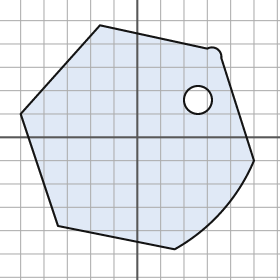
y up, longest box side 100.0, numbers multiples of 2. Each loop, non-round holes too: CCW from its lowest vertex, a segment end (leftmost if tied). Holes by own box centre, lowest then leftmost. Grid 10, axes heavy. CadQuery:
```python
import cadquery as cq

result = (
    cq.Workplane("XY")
    .moveTo(16.0, -48.0)
    .threePointArc((36.0, -32.0), (50.0, -10.0))
    .lineTo(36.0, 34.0)
    .threePointArc((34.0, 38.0), (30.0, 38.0))
    .lineTo(-16.0, 48.0)
    .lineTo(-50.0, 10.0)
    .lineTo(-34.0, -38.0)
    .close()
    .moveTo(26.0, 16.0)
    .circle(6.0)
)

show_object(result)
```